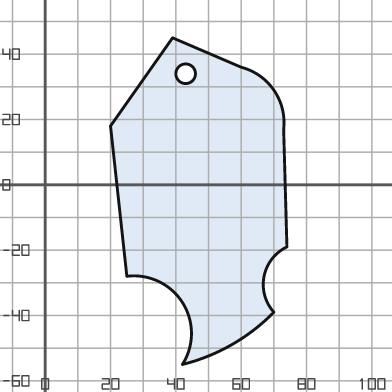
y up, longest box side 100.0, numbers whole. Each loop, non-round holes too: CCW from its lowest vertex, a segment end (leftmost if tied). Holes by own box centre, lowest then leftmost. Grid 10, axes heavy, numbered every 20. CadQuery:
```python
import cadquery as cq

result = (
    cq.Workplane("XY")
    .moveTo(42.0, -55.0)
    .threePointArc((57.0, -49.0), (70.0, -39.0))
    .threePointArc((67.0, -28.0), (74.0, -19.0))
    .lineTo(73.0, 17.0)
    .threePointArc((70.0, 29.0), (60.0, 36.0))
    .lineTo(39.0, 45.0)
    .lineTo(20.0, 18.0)
    .lineTo(25.0, -28.0)
    .threePointArc((42.0, -36.0), (42.0, -55.0))
    .close()
    .moveTo(43.0, 34.0)
    .circle(3.0)
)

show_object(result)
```